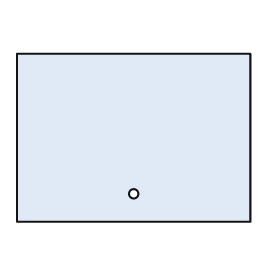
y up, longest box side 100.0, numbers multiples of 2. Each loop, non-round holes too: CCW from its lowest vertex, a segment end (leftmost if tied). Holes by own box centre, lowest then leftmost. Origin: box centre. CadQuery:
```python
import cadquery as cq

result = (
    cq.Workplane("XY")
    .moveTo(-50.0, -36.0)
    .lineTo(50.0, -36.0)
    .lineTo(50.0, 36.0)
    .lineTo(-50.0, 36.0)
    .close()
    .moveTo(0.0, -24.0)
    .circle(2.0)
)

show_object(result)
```